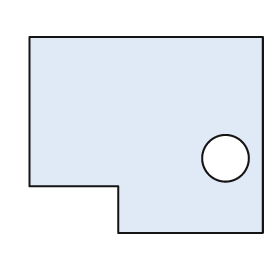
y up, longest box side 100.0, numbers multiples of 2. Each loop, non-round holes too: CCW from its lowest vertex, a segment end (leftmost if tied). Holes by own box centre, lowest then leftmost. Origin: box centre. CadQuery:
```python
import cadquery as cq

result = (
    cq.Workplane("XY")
    .moveTo(-12.0, -42.0)
    .lineTo(50.0, -42.0)
    .lineTo(50.0, 42.0)
    .lineTo(-50.0, 42.0)
    .lineTo(-50.0, -22.0)
    .lineTo(-12.0, -22.0)
    .close()
    .moveTo(34.0, -10.0)
    .circle(10.0)
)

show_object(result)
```